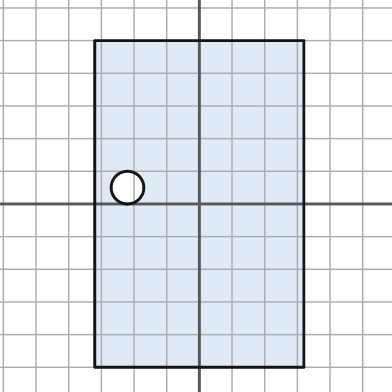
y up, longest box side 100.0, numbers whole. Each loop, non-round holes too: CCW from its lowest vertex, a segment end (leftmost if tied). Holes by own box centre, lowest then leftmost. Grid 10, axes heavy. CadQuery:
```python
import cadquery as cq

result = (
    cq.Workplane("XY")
    .moveTo(-32.0, -50.0)
    .lineTo(32.0, -50.0)
    .lineTo(32.0, 50.0)
    .lineTo(-32.0, 50.0)
    .close()
    .moveTo(-22.0, 5.0)
    .circle(5.0)
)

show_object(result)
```